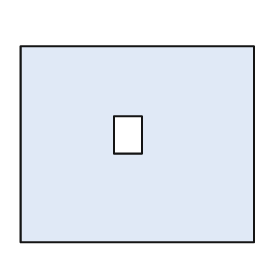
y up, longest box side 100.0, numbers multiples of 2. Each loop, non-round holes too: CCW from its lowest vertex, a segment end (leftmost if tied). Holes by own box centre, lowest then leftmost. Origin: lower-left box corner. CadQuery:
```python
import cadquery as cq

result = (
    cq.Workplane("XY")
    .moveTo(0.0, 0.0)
    .lineTo(100.0, 0.0)
    .lineTo(100.0, 84.0)
    .lineTo(0.0, 84.0)
    .close()
    .moveTo(40.0, 38.0)
    .lineTo(52.0, 38.0)
    .lineTo(52.0, 54.0)
    .lineTo(40.0, 54.0)
    .close()
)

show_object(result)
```